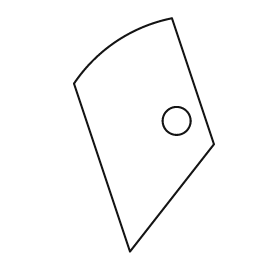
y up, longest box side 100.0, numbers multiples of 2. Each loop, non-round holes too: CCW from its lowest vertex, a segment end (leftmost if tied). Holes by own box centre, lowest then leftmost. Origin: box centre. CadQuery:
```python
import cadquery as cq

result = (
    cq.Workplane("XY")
    .moveTo(-6.0, -50.0)
    .lineTo(30.0, -4.0)
    .lineTo(12.0, 50.0)
    .threePointArc((-12.0, 40.0), (-30.0, 22.0))
    .close()
    .moveTo(14.0, 6.0)
    .circle(6.0)
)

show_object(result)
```